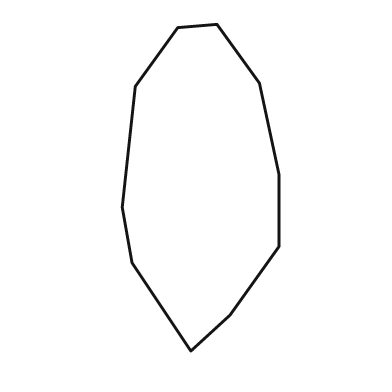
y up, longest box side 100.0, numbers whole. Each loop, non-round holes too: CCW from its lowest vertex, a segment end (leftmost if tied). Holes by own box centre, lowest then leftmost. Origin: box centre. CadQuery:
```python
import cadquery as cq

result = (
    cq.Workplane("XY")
    .moveTo(-3.0, -50.0)
    .lineTo(9.0, -39.0)
    .lineTo(24.0, -18.0)
    .lineTo(24.0, 4.0)
    .lineTo(18.0, 32.0)
    .lineTo(5.0, 50.0)
    .lineTo(-7.0, 49.0)
    .lineTo(-20.0, 31.0)
    .lineTo(-24.0, -6.0)
    .lineTo(-21.0, -23.0)
    .close()
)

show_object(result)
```